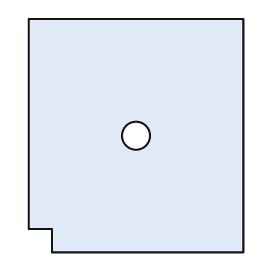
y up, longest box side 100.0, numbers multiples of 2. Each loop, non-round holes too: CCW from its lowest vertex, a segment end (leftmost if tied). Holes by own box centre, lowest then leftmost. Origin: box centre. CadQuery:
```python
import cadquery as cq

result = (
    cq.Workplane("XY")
    .moveTo(-36.0, -50.0)
    .lineTo(46.0, -50.0)
    .lineTo(46.0, 50.0)
    .lineTo(-46.0, 50.0)
    .lineTo(-46.0, -40.0)
    .lineTo(-36.0, -40.0)
    .close()
    .moveTo(0.0, 0.0)
    .circle(6.0)
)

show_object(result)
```